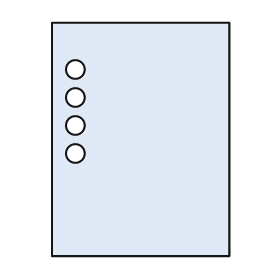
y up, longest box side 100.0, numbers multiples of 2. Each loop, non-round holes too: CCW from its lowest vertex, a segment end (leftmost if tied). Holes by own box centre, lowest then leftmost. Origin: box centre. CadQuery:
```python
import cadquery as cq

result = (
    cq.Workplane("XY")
    .moveTo(-38.0, -50.0)
    .lineTo(38.0, -50.0)
    .lineTo(38.0, 50.0)
    .lineTo(-38.0, 50.0)
    .close()
    .moveTo(-28.0, -6.0)
    .circle(4.0)
    .moveTo(-28.0, 6.0)
    .circle(4.0)
    .moveTo(-28.0, 18.0)
    .circle(4.0)
    .moveTo(-28.0, 30.0)
    .circle(4.0)
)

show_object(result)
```